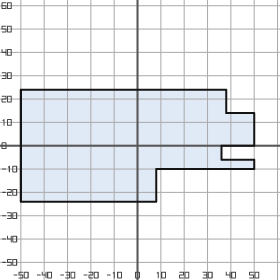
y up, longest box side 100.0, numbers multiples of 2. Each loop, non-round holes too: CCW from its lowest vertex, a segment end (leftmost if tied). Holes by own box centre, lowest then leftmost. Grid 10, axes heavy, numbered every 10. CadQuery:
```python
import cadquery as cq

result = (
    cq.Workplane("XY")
    .moveTo(-50.0, -24.0)
    .lineTo(8.0, -24.0)
    .lineTo(8.0, -10.0)
    .lineTo(50.0, -10.0)
    .lineTo(50.0, -6.0)
    .lineTo(36.0, -6.0)
    .lineTo(36.0, 0.0)
    .lineTo(50.0, 0.0)
    .lineTo(50.0, 14.0)
    .lineTo(38.0, 14.0)
    .lineTo(38.0, 24.0)
    .lineTo(-50.0, 24.0)
    .close()
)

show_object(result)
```